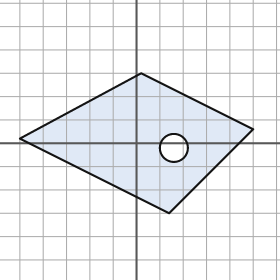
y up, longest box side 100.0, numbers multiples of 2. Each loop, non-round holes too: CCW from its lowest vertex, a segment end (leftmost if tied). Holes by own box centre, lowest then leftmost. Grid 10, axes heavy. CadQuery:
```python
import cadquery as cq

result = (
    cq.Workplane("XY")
    .moveTo(14.0, -30.0)
    .lineTo(50.0, 6.0)
    .lineTo(2.0, 30.0)
    .lineTo(-50.0, 2.0)
    .close()
    .moveTo(16.0, -2.0)
    .circle(6.0)
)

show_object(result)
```